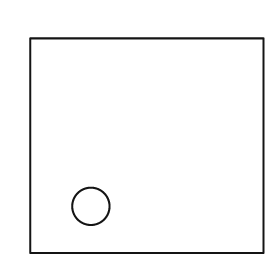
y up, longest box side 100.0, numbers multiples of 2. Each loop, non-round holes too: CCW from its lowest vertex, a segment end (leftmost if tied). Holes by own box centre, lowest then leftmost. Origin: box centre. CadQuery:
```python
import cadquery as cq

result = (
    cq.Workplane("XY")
    .moveTo(-50.0, -46.0)
    .lineTo(50.0, -46.0)
    .lineTo(50.0, 46.0)
    .lineTo(-50.0, 46.0)
    .close()
    .moveTo(-24.0, -26.0)
    .circle(8.0)
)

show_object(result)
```